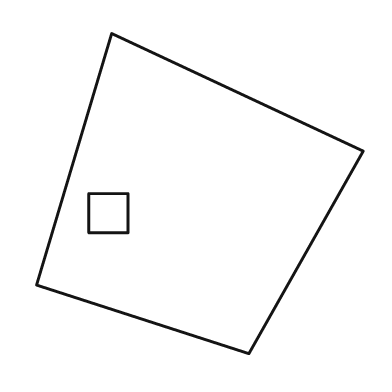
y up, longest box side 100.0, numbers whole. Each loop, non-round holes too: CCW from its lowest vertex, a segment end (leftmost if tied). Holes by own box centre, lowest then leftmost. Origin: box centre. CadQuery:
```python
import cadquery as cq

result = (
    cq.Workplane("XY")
    .moveTo(15.0, -49.0)
    .lineTo(50.0, 13.0)
    .lineTo(-27.0, 49.0)
    .lineTo(-50.0, -28.0)
    .close()
    .moveTo(-34.0, -12.0)
    .lineTo(-22.0, -12.0)
    .lineTo(-22.0, 0.0)
    .lineTo(-34.0, 0.0)
    .close()
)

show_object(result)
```